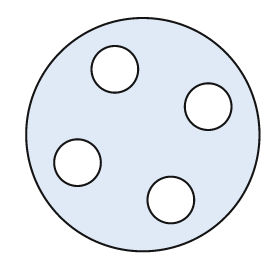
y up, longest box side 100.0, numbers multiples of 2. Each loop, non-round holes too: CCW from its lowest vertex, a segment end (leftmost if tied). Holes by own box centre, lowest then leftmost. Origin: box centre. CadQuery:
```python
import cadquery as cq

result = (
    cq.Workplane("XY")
    .moveTo(0.0, 0.0)
    .circle(50.0)
    .moveTo(12.0, -28.0)
    .circle(10.0)
    .moveTo(-28.0, -12.0)
    .circle(10.0)
    .moveTo(28.0, 12.0)
    .circle(10.0)
    .moveTo(-12.0, 28.0)
    .circle(10.0)
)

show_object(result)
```